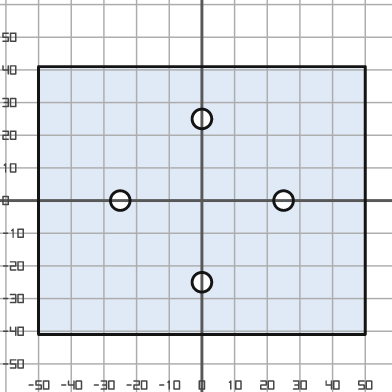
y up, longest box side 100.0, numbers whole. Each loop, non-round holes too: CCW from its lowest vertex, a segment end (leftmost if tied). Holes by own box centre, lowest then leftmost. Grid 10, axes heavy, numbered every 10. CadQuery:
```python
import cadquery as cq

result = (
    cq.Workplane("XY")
    .moveTo(-50.0, -41.0)
    .lineTo(50.0, -41.0)
    .lineTo(50.0, 41.0)
    .lineTo(-50.0, 41.0)
    .close()
    .moveTo(0.0, -25.0)
    .circle(3.0)
    .moveTo(-25.0, 0.0)
    .circle(3.0)
    .moveTo(25.0, 0.0)
    .circle(3.0)
    .moveTo(0.0, 25.0)
    .circle(3.0)
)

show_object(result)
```